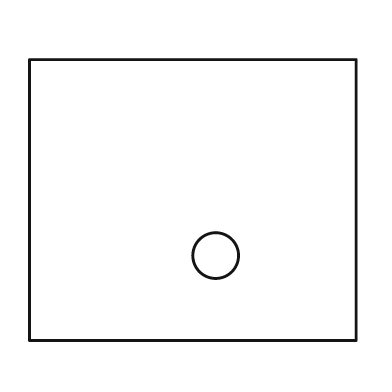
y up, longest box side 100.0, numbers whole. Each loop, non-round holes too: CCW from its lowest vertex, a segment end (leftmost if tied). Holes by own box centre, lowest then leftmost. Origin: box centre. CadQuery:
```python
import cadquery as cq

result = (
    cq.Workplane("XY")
    .moveTo(-50.0, -43.0)
    .lineTo(50.0, -43.0)
    .lineTo(50.0, 43.0)
    .lineTo(-50.0, 43.0)
    .close()
    .moveTo(7.0, -17.0)
    .circle(7.0)
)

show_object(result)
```